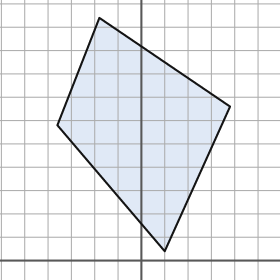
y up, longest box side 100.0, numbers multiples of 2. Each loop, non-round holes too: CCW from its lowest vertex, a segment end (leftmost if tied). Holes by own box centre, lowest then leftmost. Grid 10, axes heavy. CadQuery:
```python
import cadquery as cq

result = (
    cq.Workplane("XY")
    .moveTo(10.0, 4.0)
    .lineTo(38.0, 66.0)
    .lineTo(-18.0, 104.0)
    .lineTo(-36.0, 58.0)
    .close()
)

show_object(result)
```